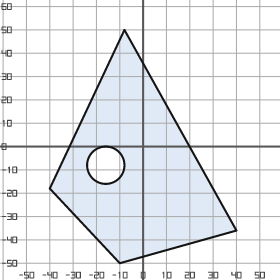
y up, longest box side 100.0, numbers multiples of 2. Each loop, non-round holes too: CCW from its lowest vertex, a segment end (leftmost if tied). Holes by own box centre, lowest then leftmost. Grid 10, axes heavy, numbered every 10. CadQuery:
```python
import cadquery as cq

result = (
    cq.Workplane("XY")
    .moveTo(-10.0, -50.0)
    .lineTo(40.0, -36.0)
    .lineTo(-8.0, 50.0)
    .lineTo(-40.0, -18.0)
    .close()
    .moveTo(-16.0, -8.0)
    .circle(8.0)
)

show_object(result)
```